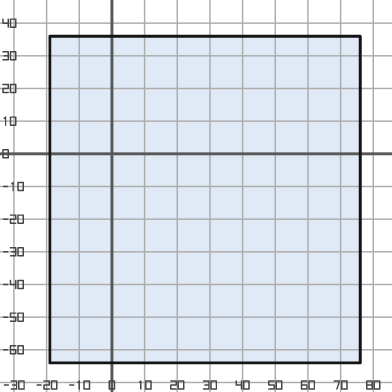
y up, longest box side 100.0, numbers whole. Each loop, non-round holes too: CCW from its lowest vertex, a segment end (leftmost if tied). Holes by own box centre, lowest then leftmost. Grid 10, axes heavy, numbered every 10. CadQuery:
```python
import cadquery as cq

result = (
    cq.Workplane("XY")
    .moveTo(-19.0, -64.0)
    .lineTo(76.0, -64.0)
    .lineTo(76.0, 36.0)
    .lineTo(-19.0, 36.0)
    .close()
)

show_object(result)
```